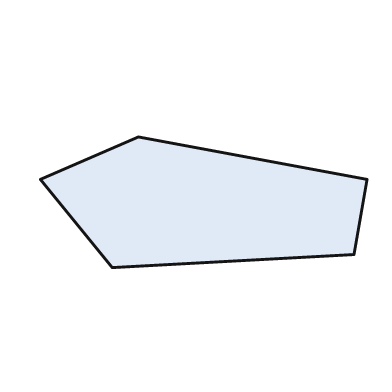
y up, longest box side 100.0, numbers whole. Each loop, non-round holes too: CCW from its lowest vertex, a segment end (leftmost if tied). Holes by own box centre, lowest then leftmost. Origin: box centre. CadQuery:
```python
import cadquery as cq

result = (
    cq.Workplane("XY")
    .moveTo(-28.0, -20.0)
    .lineTo(46.0, -16.0)
    .lineTo(50.0, 7.0)
    .lineTo(-20.0, 20.0)
    .lineTo(-50.0, 7.0)
    .close()
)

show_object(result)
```